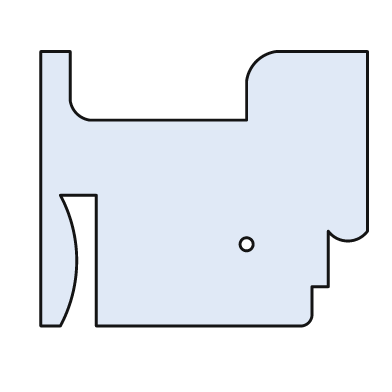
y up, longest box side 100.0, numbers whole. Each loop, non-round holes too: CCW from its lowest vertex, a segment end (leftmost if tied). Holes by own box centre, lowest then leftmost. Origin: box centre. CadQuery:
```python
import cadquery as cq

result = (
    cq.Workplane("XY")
    .moveTo(-50.0, -42.0)
    .lineTo(-44.0, -42.0)
    .threePointArc((-39.0, -22.0), (-44.0, -2.0))
    .lineTo(-33.0, -2.0)
    .lineTo(-33.0, -42.0)
    .lineTo(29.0, -42.0)
    .threePointArc((32.0, -41.0), (33.0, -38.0))
    .lineTo(33.0, -30.0)
    .lineTo(38.0, -30.0)
    .lineTo(38.0, -13.0)
    .threePointArc((44.0, -16.0), (50.0, -13.0))
    .lineTo(50.0, 42.0)
    .lineTo(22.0, 42.0)
    .threePointArc((16.0, 39.0), (13.0, 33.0))
    .lineTo(13.0, 21.0)
    .lineTo(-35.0, 21.0)
    .threePointArc((-39.0, 23.0), (-41.0, 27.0))
    .lineTo(-41.0, 42.0)
    .lineTo(-50.0, 42.0)
    .close()
    .moveTo(13.0, -17.0)
    .circle(2.0)
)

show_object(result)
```